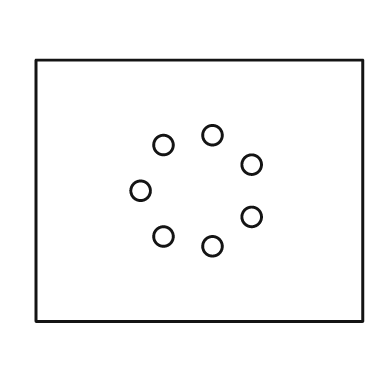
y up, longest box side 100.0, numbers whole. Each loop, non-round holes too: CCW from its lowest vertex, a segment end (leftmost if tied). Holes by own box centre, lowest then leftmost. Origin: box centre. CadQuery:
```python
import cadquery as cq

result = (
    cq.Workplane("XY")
    .moveTo(-50.0, -40.0)
    .lineTo(50.0, -40.0)
    .lineTo(50.0, 40.0)
    .lineTo(-50.0, 40.0)
    .close()
    .moveTo(4.0, -17.0)
    .circle(3.0)
    .moveTo(-11.0, -14.0)
    .circle(3.0)
    .moveTo(16.0, -8.0)
    .circle(3.0)
    .moveTo(-18.0, 0.0)
    .circle(3.0)
    .moveTo(16.0, 8.0)
    .circle(3.0)
    .moveTo(-11.0, 14.0)
    .circle(3.0)
    .moveTo(4.0, 17.0)
    .circle(3.0)
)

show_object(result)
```